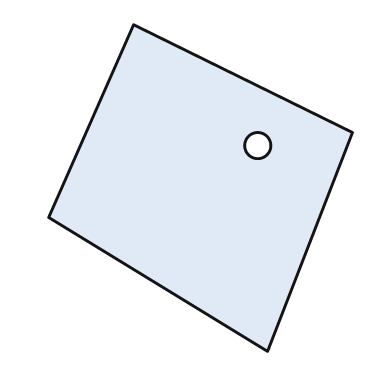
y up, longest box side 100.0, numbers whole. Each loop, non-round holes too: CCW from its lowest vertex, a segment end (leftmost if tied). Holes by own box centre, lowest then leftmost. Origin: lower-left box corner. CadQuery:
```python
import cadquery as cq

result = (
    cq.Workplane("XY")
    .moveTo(67.0, 0.0)
    .lineTo(93.0, 67.0)
    .lineTo(26.0, 100.0)
    .lineTo(0.0, 41.0)
    .close()
    .moveTo(64.0, 63.0)
    .circle(4.0)
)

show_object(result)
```